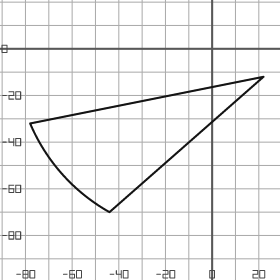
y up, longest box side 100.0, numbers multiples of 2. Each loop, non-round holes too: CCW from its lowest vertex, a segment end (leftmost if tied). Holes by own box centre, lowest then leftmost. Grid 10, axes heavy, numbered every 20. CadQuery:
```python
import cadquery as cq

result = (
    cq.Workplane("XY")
    .moveTo(-44.0, -70.0)
    .lineTo(22.0, -12.0)
    .lineTo(-78.0, -32.0)
    .threePointArc((-64.0, -54.0), (-44.0, -70.0))
    .close()
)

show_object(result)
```